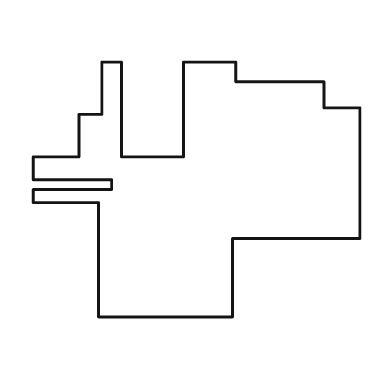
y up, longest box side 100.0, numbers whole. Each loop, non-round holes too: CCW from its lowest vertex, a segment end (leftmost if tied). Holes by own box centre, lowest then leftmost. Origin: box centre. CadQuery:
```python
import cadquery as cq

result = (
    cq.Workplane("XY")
    .moveTo(-30.0, -39.0)
    .lineTo(11.0, -39.0)
    .lineTo(11.0, -15.0)
    .lineTo(50.0, -15.0)
    .lineTo(50.0, 25.0)
    .lineTo(39.0, 25.0)
    .lineTo(39.0, 33.0)
    .lineTo(12.0, 33.0)
    .lineTo(12.0, 39.0)
    .lineTo(-4.0, 39.0)
    .lineTo(-4.0, 10.0)
    .lineTo(-23.0, 10.0)
    .lineTo(-23.0, 39.0)
    .lineTo(-29.0, 39.0)
    .lineTo(-29.0, 23.0)
    .lineTo(-36.0, 23.0)
    .lineTo(-36.0, 10.0)
    .lineTo(-50.0, 10.0)
    .lineTo(-50.0, 3.0)
    .lineTo(-26.0, 3.0)
    .lineTo(-26.0, 0.0)
    .lineTo(-50.0, 0.0)
    .lineTo(-50.0, -4.0)
    .lineTo(-30.0, -4.0)
    .close()
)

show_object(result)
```